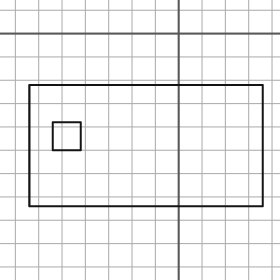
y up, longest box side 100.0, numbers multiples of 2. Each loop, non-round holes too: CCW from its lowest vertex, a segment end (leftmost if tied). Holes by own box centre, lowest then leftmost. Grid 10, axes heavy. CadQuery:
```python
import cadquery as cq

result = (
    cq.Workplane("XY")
    .moveTo(-64.0, -74.0)
    .lineTo(36.0, -74.0)
    .lineTo(36.0, -22.0)
    .lineTo(-64.0, -22.0)
    .close()
    .moveTo(-54.0, -50.0)
    .lineTo(-42.0, -50.0)
    .lineTo(-42.0, -38.0)
    .lineTo(-54.0, -38.0)
    .close()
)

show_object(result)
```